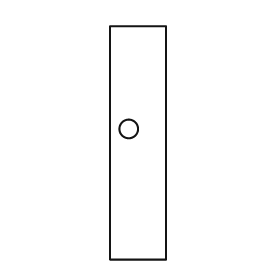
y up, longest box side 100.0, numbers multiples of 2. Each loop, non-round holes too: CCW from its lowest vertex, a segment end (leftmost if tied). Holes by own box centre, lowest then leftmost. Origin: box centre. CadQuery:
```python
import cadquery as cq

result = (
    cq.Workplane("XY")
    .moveTo(-12.0, -50.0)
    .lineTo(12.0, -50.0)
    .lineTo(12.0, 50.0)
    .lineTo(-12.0, 50.0)
    .close()
    .moveTo(-4.0, 6.0)
    .circle(4.0)
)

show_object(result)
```